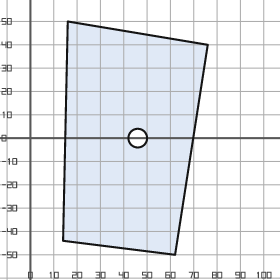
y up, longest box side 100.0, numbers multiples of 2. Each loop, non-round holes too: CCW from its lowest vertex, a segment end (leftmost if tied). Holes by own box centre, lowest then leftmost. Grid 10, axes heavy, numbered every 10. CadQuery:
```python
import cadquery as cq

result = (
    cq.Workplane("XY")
    .moveTo(62.0, -50.0)
    .lineTo(76.0, 40.0)
    .lineTo(16.0, 50.0)
    .lineTo(14.0, -44.0)
    .close()
    .moveTo(46.0, 0.0)
    .circle(4.0)
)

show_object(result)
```